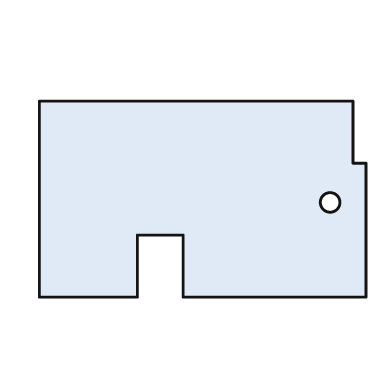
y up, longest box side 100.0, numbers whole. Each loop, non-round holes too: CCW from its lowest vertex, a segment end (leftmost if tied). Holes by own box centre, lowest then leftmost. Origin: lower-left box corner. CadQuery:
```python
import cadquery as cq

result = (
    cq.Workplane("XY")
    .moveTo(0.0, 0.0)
    .lineTo(30.0, 0.0)
    .lineTo(30.0, 19.0)
    .lineTo(44.0, 19.0)
    .lineTo(44.0, 0.0)
    .lineTo(100.0, 0.0)
    .lineTo(100.0, 41.0)
    .lineTo(96.0, 41.0)
    .lineTo(96.0, 60.0)
    .lineTo(0.0, 60.0)
    .close()
    .moveTo(89.0, 29.0)
    .circle(3.0)
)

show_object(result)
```